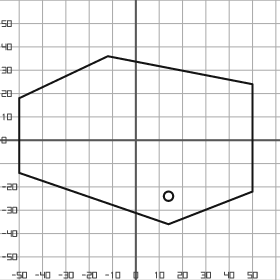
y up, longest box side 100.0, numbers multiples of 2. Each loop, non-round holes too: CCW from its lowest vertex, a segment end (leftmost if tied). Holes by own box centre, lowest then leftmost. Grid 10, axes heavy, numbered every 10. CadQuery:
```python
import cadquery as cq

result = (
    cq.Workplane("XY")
    .moveTo(14.0, -36.0)
    .lineTo(50.0, -22.0)
    .lineTo(50.0, 24.0)
    .lineTo(-12.0, 36.0)
    .lineTo(-50.0, 18.0)
    .lineTo(-50.0, -14.0)
    .close()
    .moveTo(14.0, -24.0)
    .circle(2.0)
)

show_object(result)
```